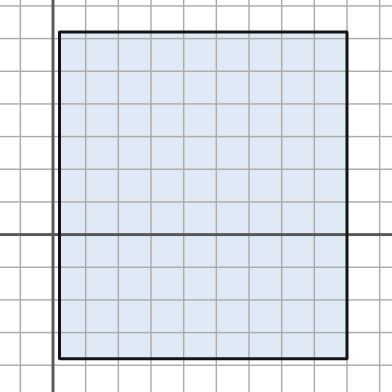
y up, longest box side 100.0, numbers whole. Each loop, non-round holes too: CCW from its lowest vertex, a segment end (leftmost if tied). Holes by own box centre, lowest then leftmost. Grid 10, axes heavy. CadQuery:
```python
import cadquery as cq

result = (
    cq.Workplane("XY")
    .moveTo(2.0, -38.0)
    .lineTo(90.0, -38.0)
    .lineTo(90.0, 62.0)
    .lineTo(2.0, 62.0)
    .close()
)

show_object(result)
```